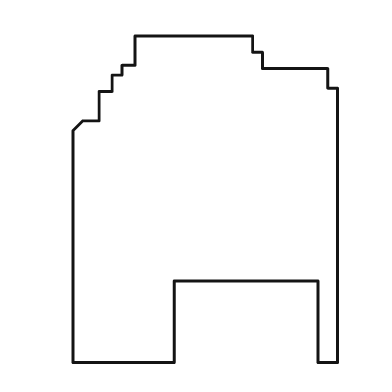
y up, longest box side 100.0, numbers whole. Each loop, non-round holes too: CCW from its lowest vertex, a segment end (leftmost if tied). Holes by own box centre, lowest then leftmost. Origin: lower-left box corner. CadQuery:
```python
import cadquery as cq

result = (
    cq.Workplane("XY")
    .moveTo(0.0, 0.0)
    .lineTo(31.0, 0.0)
    .lineTo(31.0, 25.0)
    .lineTo(75.0, 25.0)
    .lineTo(75.0, 0.0)
    .lineTo(81.0, 0.0)
    .lineTo(81.0, 84.0)
    .lineTo(78.0, 84.0)
    .lineTo(78.0, 90.0)
    .lineTo(58.0, 90.0)
    .lineTo(58.0, 95.0)
    .lineTo(55.0, 95.0)
    .lineTo(55.0, 100.0)
    .lineTo(19.0, 100.0)
    .lineTo(19.0, 91.0)
    .lineTo(15.0, 91.0)
    .lineTo(15.0, 88.0)
    .lineTo(12.0, 88.0)
    .lineTo(12.0, 83.0)
    .lineTo(8.0, 83.0)
    .lineTo(8.0, 74.0)
    .lineTo(3.0, 74.0)
    .lineTo(0.0, 71.0)
    .close()
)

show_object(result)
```